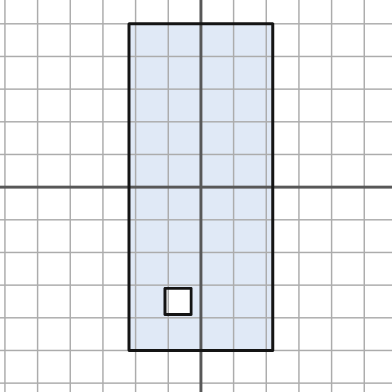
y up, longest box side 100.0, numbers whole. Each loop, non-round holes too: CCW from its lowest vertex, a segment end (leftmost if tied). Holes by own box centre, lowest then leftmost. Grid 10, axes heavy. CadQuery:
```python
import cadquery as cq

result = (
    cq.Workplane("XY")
    .moveTo(-22.0, -50.0)
    .lineTo(22.0, -50.0)
    .lineTo(22.0, 50.0)
    .lineTo(-22.0, 50.0)
    .close()
    .moveTo(-11.0, -39.0)
    .lineTo(-3.0, -39.0)
    .lineTo(-3.0, -31.0)
    .lineTo(-11.0, -31.0)
    .close()
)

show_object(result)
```